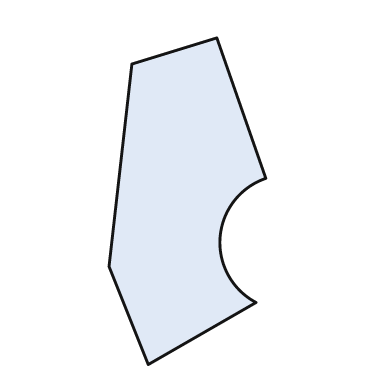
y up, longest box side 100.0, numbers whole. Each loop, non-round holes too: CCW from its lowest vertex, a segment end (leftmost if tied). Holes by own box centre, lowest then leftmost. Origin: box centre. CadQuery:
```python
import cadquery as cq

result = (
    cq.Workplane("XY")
    .moveTo(-12.0, -50.0)
    .lineTo(21.0, -31.0)
    .threePointArc((10.0, -11.0), (24.0, 7.0))
    .lineTo(9.0, 50.0)
    .lineTo(-17.0, 42.0)
    .lineTo(-24.0, -20.0)
    .close()
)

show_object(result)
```